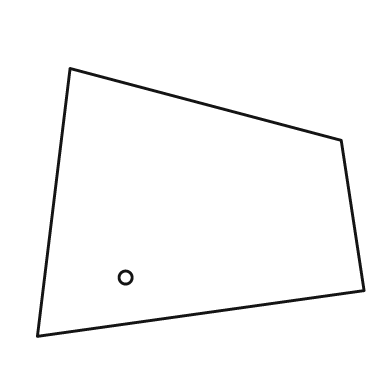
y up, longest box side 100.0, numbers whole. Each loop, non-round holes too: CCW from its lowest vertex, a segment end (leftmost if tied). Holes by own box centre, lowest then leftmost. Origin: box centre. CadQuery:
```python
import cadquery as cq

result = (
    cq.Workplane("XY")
    .moveTo(-50.0, -41.0)
    .lineTo(50.0, -27.0)
    .lineTo(43.0, 19.0)
    .lineTo(-40.0, 41.0)
    .close()
    .moveTo(-23.0, -23.0)
    .circle(2.0)
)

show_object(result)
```